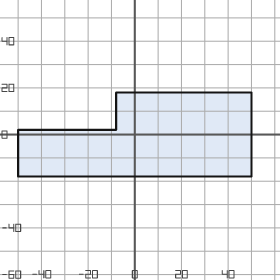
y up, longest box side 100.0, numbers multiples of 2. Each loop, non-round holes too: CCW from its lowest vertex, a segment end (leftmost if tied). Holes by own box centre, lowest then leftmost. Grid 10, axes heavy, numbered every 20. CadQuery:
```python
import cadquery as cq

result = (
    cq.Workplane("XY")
    .moveTo(-50.0, -18.0)
    .lineTo(50.0, -18.0)
    .lineTo(50.0, 18.0)
    .lineTo(-8.0, 18.0)
    .lineTo(-8.0, 2.0)
    .lineTo(-50.0, 2.0)
    .close()
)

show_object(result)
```